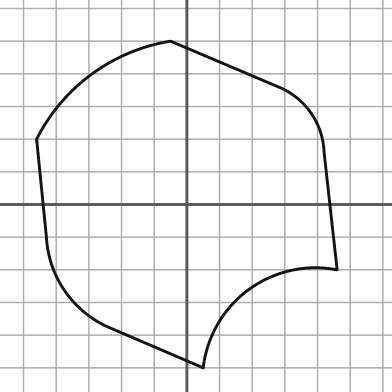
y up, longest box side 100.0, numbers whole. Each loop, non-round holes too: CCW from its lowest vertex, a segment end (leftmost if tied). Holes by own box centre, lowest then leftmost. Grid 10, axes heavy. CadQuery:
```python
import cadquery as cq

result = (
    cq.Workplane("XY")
    .moveTo(5.0, -50.0)
    .threePointArc((19.0, -26.0), (46.0, -20.0))
    .lineTo(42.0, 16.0)
    .threePointArc((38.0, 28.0), (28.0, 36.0))
    .lineTo(-5.0, 50.0)
    .threePointArc((-29.0, 40.0), (-46.0, 20.0))
    .lineTo(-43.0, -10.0)
    .threePointArc((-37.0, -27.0), (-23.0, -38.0))
    .close()
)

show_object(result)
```